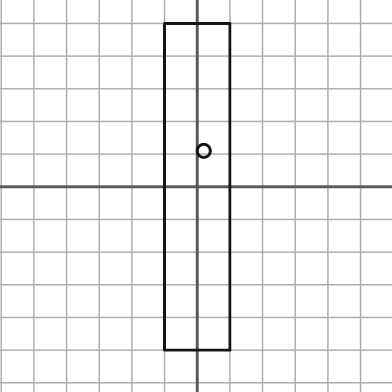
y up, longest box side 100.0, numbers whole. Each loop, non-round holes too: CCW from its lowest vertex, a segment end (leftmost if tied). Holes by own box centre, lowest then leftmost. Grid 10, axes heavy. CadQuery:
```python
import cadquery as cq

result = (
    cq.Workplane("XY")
    .moveTo(-10.0, -50.0)
    .lineTo(10.0, -50.0)
    .lineTo(10.0, 50.0)
    .lineTo(-10.0, 50.0)
    .close()
    .moveTo(2.0, 11.0)
    .circle(2.0)
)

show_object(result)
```